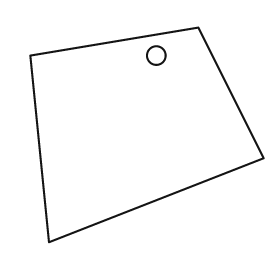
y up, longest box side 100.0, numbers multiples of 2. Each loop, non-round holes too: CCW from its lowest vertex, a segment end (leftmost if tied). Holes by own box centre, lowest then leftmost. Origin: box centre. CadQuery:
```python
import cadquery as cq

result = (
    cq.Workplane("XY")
    .moveTo(-42.0, -46.0)
    .lineTo(50.0, -10.0)
    .lineTo(22.0, 46.0)
    .lineTo(-50.0, 34.0)
    .close()
    .moveTo(4.0, 34.0)
    .circle(4.0)
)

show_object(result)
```